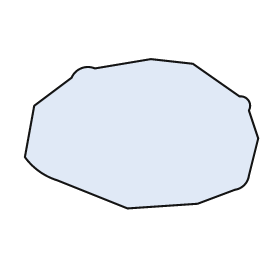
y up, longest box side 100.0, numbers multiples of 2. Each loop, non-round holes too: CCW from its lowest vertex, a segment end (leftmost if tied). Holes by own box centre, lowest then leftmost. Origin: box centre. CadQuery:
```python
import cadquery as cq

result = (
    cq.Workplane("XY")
    .moveTo(-6.0, -32.0)
    .lineTo(24.0, -30.0)
    .lineTo(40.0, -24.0)
    .threePointArc((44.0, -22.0), (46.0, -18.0))
    .lineTo(50.0, -2.0)
    .lineTo(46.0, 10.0)
    .threePointArc((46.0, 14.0), (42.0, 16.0))
    .lineTo(22.0, 30.0)
    .lineTo(4.0, 32.0)
    .lineTo(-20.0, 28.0)
    .threePointArc((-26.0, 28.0), (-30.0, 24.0))
    .lineTo(-46.0, 12.0)
    .lineTo(-50.0, -10.0)
    .threePointArc((-44.0, -16.0), (-36.0, -20.0))
    .close()
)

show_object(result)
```